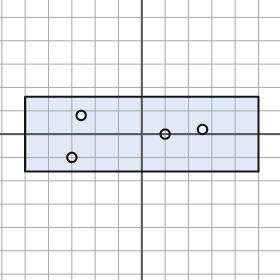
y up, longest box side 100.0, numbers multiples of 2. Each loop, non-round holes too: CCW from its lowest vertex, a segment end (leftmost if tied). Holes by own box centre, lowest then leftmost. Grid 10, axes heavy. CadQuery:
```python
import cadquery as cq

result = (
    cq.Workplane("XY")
    .moveTo(-50.0, -16.0)
    .lineTo(50.0, -16.0)
    .lineTo(50.0, 16.0)
    .lineTo(-50.0, 16.0)
    .close()
    .moveTo(-30.0, -10.0)
    .circle(2.0)
    .moveTo(10.0, 0.0)
    .circle(2.0)
    .moveTo(26.0, 2.0)
    .circle(2.0)
    .moveTo(-26.0, 8.0)
    .circle(2.0)
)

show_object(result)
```